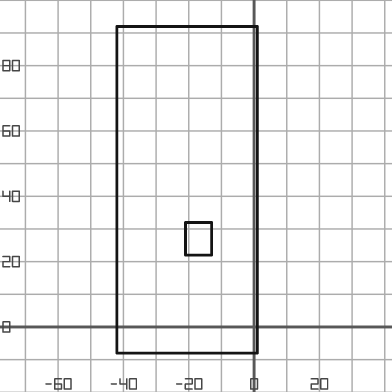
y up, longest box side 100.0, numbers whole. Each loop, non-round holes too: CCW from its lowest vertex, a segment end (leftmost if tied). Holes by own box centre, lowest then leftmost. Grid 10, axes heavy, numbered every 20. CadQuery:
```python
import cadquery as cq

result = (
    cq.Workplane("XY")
    .moveTo(-42.0, -8.0)
    .lineTo(1.0, -8.0)
    .lineTo(1.0, 92.0)
    .lineTo(-42.0, 92.0)
    .close()
    .moveTo(-21.0, 22.0)
    .lineTo(-13.0, 22.0)
    .lineTo(-13.0, 32.0)
    .lineTo(-21.0, 32.0)
    .close()
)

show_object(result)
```